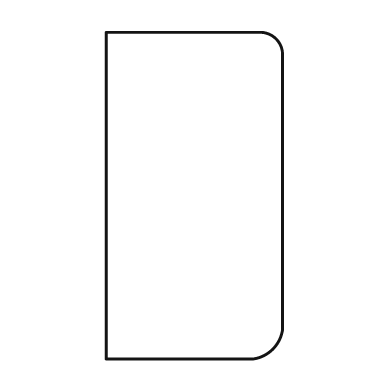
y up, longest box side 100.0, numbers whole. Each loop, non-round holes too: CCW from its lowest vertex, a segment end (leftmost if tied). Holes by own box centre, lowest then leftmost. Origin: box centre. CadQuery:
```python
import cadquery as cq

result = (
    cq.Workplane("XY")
    .moveTo(-27.0, -50.0)
    .lineTo(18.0, -50.0)
    .threePointArc((24.0, -47.0), (27.0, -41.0))
    .lineTo(27.0, 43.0)
    .threePointArc((25.0, 48.0), (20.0, 50.0))
    .lineTo(-27.0, 50.0)
    .close()
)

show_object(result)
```